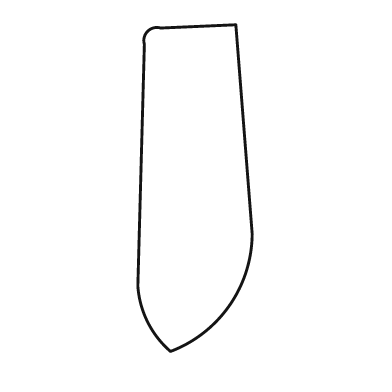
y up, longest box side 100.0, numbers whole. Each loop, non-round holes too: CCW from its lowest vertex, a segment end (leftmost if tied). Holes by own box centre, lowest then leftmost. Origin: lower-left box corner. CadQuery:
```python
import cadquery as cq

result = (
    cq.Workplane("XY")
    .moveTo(10.0, 0.0)
    .threePointArc((28.0, 14.0), (35.0, 36.0))
    .lineTo(30.0, 100.0)
    .lineTo(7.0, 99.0)
    .threePointArc((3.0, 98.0), (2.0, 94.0))
    .lineTo(0.0, 20.0)
    .threePointArc((3.0, 9.0), (10.0, 0.0))
    .close()
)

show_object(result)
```